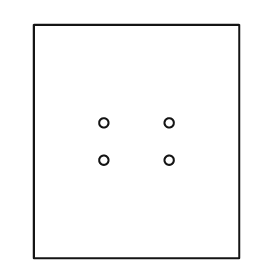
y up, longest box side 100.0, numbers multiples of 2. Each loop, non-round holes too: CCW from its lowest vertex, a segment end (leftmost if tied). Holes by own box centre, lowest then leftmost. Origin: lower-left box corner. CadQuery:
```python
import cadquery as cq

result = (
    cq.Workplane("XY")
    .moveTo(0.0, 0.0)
    .lineTo(88.0, 0.0)
    .lineTo(88.0, 100.0)
    .lineTo(0.0, 100.0)
    .close()
    .moveTo(30.0, 42.0)
    .circle(2.0)
    .moveTo(58.0, 42.0)
    .circle(2.0)
    .moveTo(30.0, 58.0)
    .circle(2.0)
    .moveTo(58.0, 58.0)
    .circle(2.0)
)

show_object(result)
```